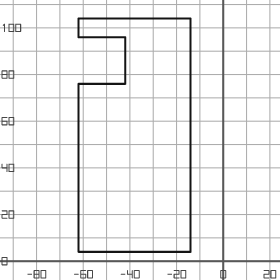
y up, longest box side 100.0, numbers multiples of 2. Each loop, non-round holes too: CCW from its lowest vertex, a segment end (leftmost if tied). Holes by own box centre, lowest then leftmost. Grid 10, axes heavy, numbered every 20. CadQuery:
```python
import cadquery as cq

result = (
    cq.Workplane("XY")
    .moveTo(-62.0, 4.0)
    .lineTo(-14.0, 4.0)
    .lineTo(-14.0, 104.0)
    .lineTo(-62.0, 104.0)
    .lineTo(-62.0, 96.0)
    .lineTo(-42.0, 96.0)
    .lineTo(-42.0, 76.0)
    .lineTo(-62.0, 76.0)
    .close()
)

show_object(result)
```